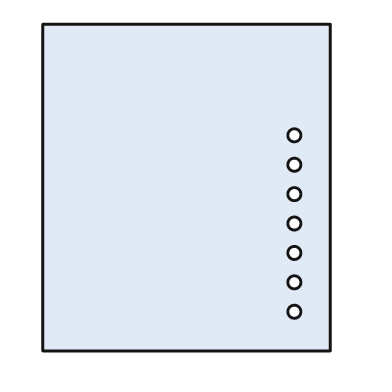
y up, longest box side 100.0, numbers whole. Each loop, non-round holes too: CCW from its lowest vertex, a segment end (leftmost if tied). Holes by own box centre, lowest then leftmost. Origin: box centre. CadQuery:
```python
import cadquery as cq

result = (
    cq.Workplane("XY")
    .moveTo(-44.0, -50.0)
    .lineTo(44.0, -50.0)
    .lineTo(44.0, 50.0)
    .lineTo(-44.0, 50.0)
    .close()
    .moveTo(33.0, -38.0)
    .circle(2.0)
    .moveTo(33.0, -29.0)
    .circle(2.0)
    .moveTo(33.0, -20.0)
    .circle(2.0)
    .moveTo(33.0, -11.0)
    .circle(2.0)
    .moveTo(33.0, -2.0)
    .circle(2.0)
    .moveTo(33.0, 7.0)
    .circle(2.0)
    .moveTo(33.0, 16.0)
    .circle(2.0)
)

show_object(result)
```